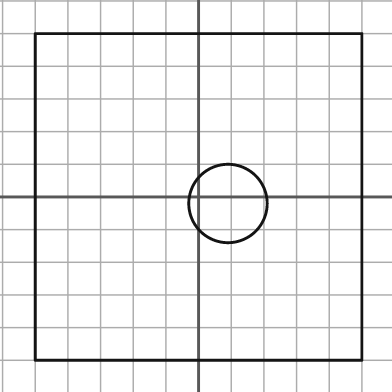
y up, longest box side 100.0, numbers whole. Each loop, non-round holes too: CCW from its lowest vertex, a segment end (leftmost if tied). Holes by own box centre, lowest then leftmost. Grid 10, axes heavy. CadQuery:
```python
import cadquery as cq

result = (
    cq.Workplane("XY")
    .moveTo(-50.0, -50.0)
    .lineTo(50.0, -50.0)
    .lineTo(50.0, 50.0)
    .lineTo(-50.0, 50.0)
    .close()
    .moveTo(9.0, -2.0)
    .circle(12.0)
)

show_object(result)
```